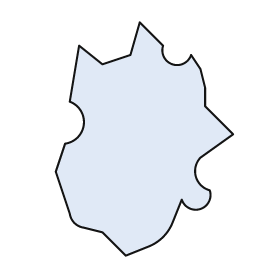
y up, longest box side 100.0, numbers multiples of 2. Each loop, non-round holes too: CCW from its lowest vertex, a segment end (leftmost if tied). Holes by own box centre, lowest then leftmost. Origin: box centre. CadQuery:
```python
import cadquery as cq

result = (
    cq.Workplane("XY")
    .moveTo(-8.0, -50.0)
    .lineTo(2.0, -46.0)
    .threePointArc((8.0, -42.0), (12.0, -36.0))
    .lineTo(16.0, -26.0)
    .threePointArc((24.0, -30.0), (28.0, -22.0))
    .threePointArc((22.0, -16.0), (24.0, -8.0))
    .lineTo(38.0, 2.0)
    .lineTo(26.0, 14.0)
    .lineTo(26.0, 22.0)
    .lineTo(24.0, 30.0)
    .lineTo(20.0, 36.0)
    .threePointArc((12.0, 32.0), (8.0, 40.0))
    .lineTo(-2.0, 50.0)
    .lineTo(-6.0, 36.0)
    .lineTo(-18.0, 32.0)
    .lineTo(-28.0, 40.0)
    .lineTo(-32.0, 16.0)
    .threePointArc((-26.0, 6.0), (-34.0, -2.0))
    .lineTo(-38.0, -14.0)
    .lineTo(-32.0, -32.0)
    .threePointArc((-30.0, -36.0), (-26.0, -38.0))
    .lineTo(-18.0, -40.0)
    .close()
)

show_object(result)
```